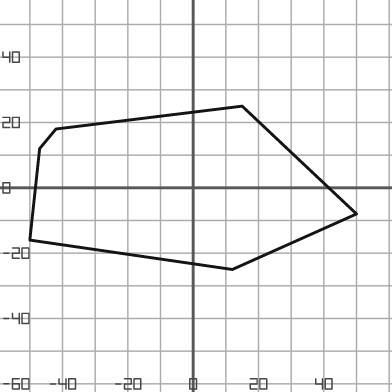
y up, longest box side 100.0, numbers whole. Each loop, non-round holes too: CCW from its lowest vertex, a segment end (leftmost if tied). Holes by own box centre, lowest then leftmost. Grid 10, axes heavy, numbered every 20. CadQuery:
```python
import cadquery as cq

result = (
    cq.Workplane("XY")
    .moveTo(12.0, -25.0)
    .lineTo(50.0, -8.0)
    .lineTo(15.0, 25.0)
    .lineTo(-42.0, 18.0)
    .lineTo(-47.0, 12.0)
    .lineTo(-50.0, -16.0)
    .close()
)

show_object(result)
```